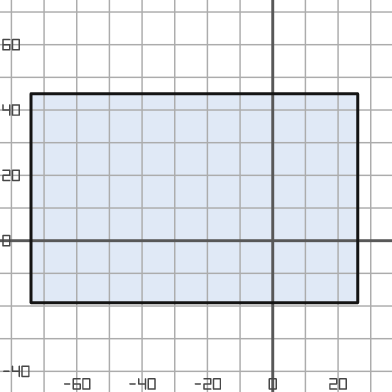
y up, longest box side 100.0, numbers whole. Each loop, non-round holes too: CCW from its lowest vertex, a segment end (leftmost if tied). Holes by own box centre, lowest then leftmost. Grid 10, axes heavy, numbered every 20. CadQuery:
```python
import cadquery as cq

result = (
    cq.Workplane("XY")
    .moveTo(-74.0, -19.0)
    .lineTo(26.0, -19.0)
    .lineTo(26.0, 45.0)
    .lineTo(-74.0, 45.0)
    .close()
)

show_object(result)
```